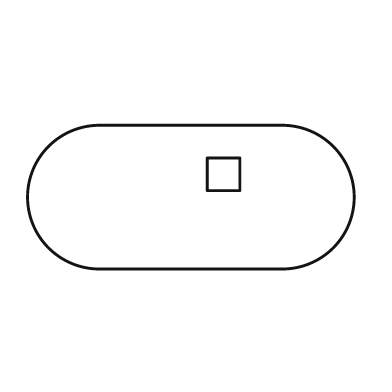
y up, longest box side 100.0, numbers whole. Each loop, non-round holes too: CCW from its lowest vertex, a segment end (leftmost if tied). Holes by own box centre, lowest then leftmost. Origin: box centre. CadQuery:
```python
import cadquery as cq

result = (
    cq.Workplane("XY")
    .moveTo(-28.0, -22.0)
    .lineTo(28.0, -22.0)
    .threePointArc((50.0, 0.0), (28.0, 22.0))
    .lineTo(-28.0, 22.0)
    .threePointArc((-50.0, 0.0), (-28.0, -22.0))
    .close()
    .moveTo(5.0, 2.0)
    .lineTo(15.0, 2.0)
    .lineTo(15.0, 12.0)
    .lineTo(5.0, 12.0)
    .close()
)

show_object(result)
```